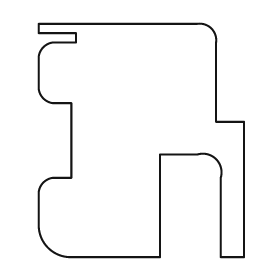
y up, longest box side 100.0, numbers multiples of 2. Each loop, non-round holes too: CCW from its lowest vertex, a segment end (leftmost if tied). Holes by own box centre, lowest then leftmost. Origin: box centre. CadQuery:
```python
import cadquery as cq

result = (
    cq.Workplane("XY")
    .moveTo(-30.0, -50.0)
    .lineTo(8.0, -50.0)
    .lineTo(8.0, -6.0)
    .lineTo(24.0, -6.0)
    .threePointArc((32.0, -8.0), (34.0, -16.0))
    .lineTo(34.0, -50.0)
    .lineTo(44.0, -50.0)
    .lineTo(44.0, 8.0)
    .lineTo(32.0, 8.0)
    .lineTo(32.0, 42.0)
    .threePointArc((30.0, 48.0), (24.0, 50.0))
    .lineTo(-44.0, 50.0)
    .lineTo(-44.0, 46.0)
    .lineTo(-28.0, 46.0)
    .lineTo(-28.0, 42.0)
    .lineTo(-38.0, 42.0)
    .threePointArc((-42.0, 40.0), (-44.0, 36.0))
    .lineTo(-44.0, 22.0)
    .threePointArc((-42.0, 18.0), (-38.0, 16.0))
    .lineTo(-30.0, 16.0)
    .lineTo(-30.0, -16.0)
    .lineTo(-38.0, -16.0)
    .threePointArc((-42.0, -18.0), (-44.0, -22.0))
    .lineTo(-44.0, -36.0)
    .threePointArc((-40.0, -46.0), (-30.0, -50.0))
    .close()
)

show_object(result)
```